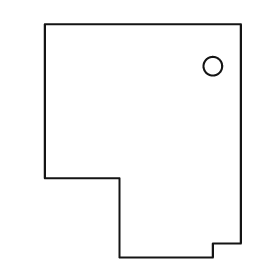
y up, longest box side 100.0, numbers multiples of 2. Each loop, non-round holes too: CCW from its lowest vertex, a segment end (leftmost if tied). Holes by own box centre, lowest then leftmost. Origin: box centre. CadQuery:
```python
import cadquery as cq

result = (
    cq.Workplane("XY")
    .moveTo(-10.0, -50.0)
    .lineTo(30.0, -50.0)
    .lineTo(30.0, -44.0)
    .lineTo(42.0, -44.0)
    .lineTo(42.0, 50.0)
    .lineTo(-42.0, 50.0)
    .lineTo(-42.0, -16.0)
    .lineTo(-10.0, -16.0)
    .close()
    .moveTo(30.0, 32.0)
    .circle(4.0)
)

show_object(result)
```